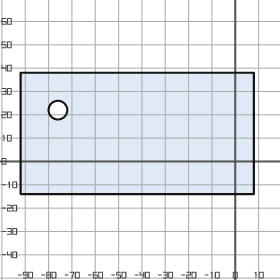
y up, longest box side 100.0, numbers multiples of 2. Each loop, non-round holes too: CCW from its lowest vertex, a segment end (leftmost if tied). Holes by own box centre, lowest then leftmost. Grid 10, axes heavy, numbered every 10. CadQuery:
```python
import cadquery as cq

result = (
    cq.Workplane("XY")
    .moveTo(-92.0, -14.0)
    .lineTo(8.0, -14.0)
    .lineTo(8.0, 38.0)
    .lineTo(-92.0, 38.0)
    .close()
    .moveTo(-76.0, 22.0)
    .circle(4.0)
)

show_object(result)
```